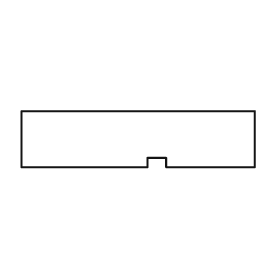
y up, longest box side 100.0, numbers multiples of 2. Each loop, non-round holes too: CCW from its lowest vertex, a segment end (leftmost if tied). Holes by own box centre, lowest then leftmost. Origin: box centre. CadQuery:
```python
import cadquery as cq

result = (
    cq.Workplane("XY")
    .moveTo(-50.0, -12.0)
    .lineTo(4.0, -12.0)
    .lineTo(4.0, -8.0)
    .lineTo(12.0, -8.0)
    .lineTo(12.0, -12.0)
    .lineTo(50.0, -12.0)
    .lineTo(50.0, 12.0)
    .lineTo(-50.0, 12.0)
    .close()
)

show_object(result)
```